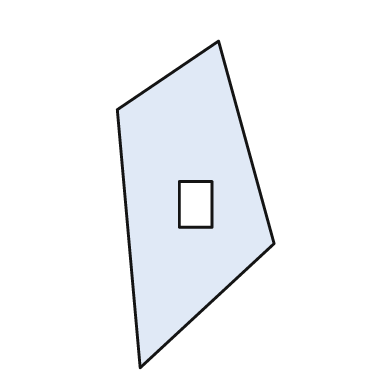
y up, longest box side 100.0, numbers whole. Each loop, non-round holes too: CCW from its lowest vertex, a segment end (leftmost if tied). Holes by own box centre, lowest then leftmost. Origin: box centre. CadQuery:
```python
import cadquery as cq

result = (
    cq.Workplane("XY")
    .moveTo(-17.0, -50.0)
    .lineTo(24.0, -12.0)
    .lineTo(7.0, 50.0)
    .lineTo(-24.0, 29.0)
    .close()
    .moveTo(-5.0, -7.0)
    .lineTo(5.0, -7.0)
    .lineTo(5.0, 7.0)
    .lineTo(-5.0, 7.0)
    .close()
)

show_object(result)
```